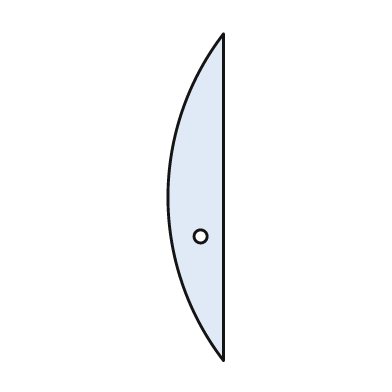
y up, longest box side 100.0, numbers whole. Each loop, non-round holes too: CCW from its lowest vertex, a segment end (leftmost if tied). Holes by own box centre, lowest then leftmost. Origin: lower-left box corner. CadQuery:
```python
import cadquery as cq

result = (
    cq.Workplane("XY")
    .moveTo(17.0, 0.0)
    .lineTo(17.0, 100.0)
    .threePointArc((0.0, 50.0), (17.0, 0.0))
    .close()
    .moveTo(10.0, 38.0)
    .circle(2.0)
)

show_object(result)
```